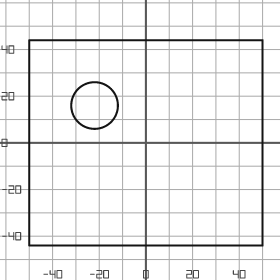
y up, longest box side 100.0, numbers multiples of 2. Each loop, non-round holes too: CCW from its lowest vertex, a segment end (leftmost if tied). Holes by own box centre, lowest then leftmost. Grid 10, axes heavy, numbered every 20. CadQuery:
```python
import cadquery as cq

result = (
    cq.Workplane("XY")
    .moveTo(-50.0, -44.0)
    .lineTo(50.0, -44.0)
    .lineTo(50.0, 44.0)
    .lineTo(-50.0, 44.0)
    .close()
    .moveTo(-22.0, 16.0)
    .circle(10.0)
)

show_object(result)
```